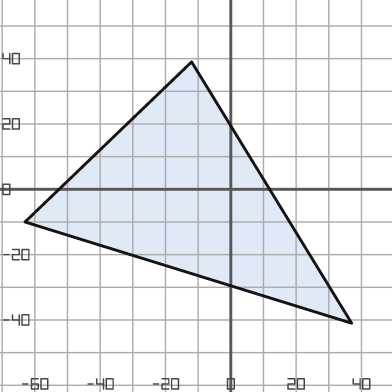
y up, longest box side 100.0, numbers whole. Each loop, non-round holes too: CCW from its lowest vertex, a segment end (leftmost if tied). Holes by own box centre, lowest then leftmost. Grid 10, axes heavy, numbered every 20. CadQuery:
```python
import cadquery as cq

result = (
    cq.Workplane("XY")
    .moveTo(37.0, -41.0)
    .lineTo(-12.0, 39.0)
    .lineTo(-63.0, -10.0)
    .close()
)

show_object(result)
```